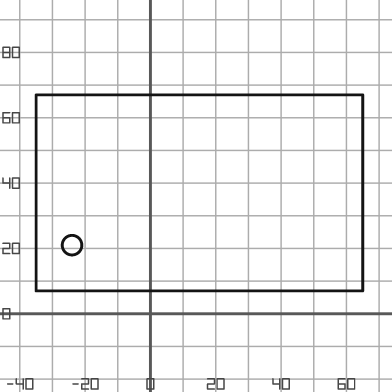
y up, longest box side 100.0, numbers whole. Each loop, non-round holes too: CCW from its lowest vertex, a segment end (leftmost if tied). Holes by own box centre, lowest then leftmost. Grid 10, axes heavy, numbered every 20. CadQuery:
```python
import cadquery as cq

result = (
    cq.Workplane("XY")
    .moveTo(-35.0, 7.0)
    .lineTo(65.0, 7.0)
    .lineTo(65.0, 67.0)
    .lineTo(-35.0, 67.0)
    .close()
    .moveTo(-24.0, 21.0)
    .circle(3.0)
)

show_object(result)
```